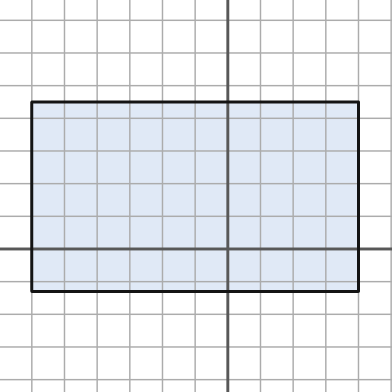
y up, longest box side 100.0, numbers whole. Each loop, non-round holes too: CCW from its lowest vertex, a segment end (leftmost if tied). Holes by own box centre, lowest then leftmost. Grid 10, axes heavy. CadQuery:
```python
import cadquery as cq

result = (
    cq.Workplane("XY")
    .moveTo(-60.0, -13.0)
    .lineTo(40.0, -13.0)
    .lineTo(40.0, 45.0)
    .lineTo(-60.0, 45.0)
    .close()
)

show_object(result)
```